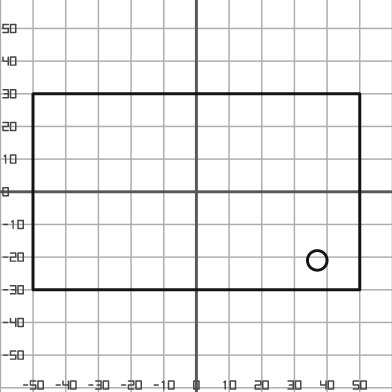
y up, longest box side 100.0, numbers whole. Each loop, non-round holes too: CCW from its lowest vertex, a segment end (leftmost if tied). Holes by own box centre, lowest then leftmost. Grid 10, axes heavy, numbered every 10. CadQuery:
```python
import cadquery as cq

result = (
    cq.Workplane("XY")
    .moveTo(-50.0, -30.0)
    .lineTo(50.0, -30.0)
    .lineTo(50.0, 30.0)
    .lineTo(-50.0, 30.0)
    .close()
    .moveTo(37.0, -21.0)
    .circle(3.0)
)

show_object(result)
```